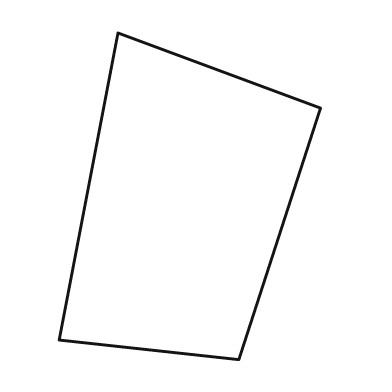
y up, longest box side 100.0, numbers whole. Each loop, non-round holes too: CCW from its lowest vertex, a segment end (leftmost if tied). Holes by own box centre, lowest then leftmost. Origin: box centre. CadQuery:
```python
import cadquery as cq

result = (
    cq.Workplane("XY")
    .moveTo(15.0, -50.0)
    .lineTo(40.0, 27.0)
    .lineTo(-22.0, 50.0)
    .lineTo(-40.0, -44.0)
    .close()
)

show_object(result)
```